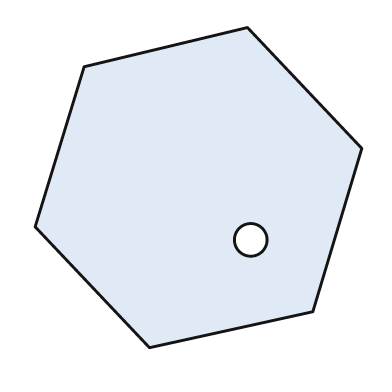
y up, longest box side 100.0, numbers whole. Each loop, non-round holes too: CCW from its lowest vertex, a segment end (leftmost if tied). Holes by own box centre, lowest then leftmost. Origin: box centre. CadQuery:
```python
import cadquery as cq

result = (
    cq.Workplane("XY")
    .moveTo(-15.0, -49.0)
    .lineTo(35.0, -38.0)
    .lineTo(50.0, 12.0)
    .lineTo(15.0, 49.0)
    .lineTo(-35.0, 37.0)
    .lineTo(-50.0, -12.0)
    .close()
    .moveTo(16.0, -16.0)
    .circle(5.0)
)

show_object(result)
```